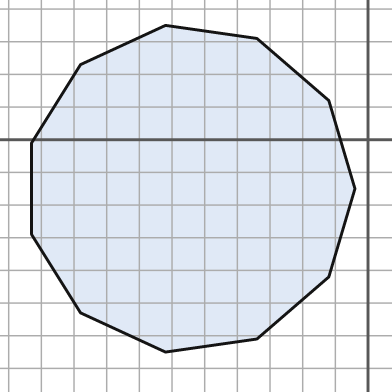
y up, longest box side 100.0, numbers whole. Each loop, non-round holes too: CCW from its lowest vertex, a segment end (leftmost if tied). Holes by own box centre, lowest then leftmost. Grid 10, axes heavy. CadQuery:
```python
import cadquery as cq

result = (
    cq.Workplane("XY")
    .moveTo(-62.0, -65.0)
    .lineTo(-34.0, -61.0)
    .lineTo(-12.0, -42.0)
    .lineTo(-4.0, -15.0)
    .lineTo(-12.0, 12.0)
    .lineTo(-34.0, 31.0)
    .lineTo(-62.0, 35.0)
    .lineTo(-88.0, 23.0)
    .lineTo(-103.0, -1.0)
    .lineTo(-103.0, -29.0)
    .lineTo(-88.0, -53.0)
    .close()
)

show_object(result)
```